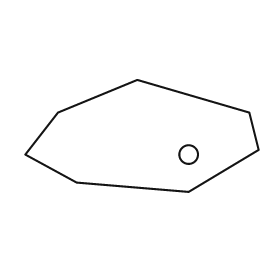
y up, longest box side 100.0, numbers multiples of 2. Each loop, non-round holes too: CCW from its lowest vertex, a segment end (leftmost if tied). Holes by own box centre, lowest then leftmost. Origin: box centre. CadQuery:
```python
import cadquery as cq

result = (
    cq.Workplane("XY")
    .moveTo(20.0, -24.0)
    .lineTo(50.0, -6.0)
    .lineTo(46.0, 10.0)
    .lineTo(-2.0, 24.0)
    .lineTo(-36.0, 10.0)
    .lineTo(-50.0, -8.0)
    .lineTo(-28.0, -20.0)
    .close()
    .moveTo(20.0, -8.0)
    .circle(4.0)
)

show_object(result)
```